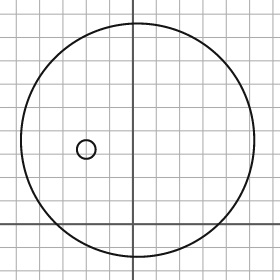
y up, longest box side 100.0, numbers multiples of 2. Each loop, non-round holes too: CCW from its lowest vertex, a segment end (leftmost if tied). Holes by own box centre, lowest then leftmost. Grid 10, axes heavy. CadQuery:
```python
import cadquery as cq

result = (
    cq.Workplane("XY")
    .moveTo(2.0, 36.0)
    .circle(50.0)
    .moveTo(-20.0, 32.0)
    .circle(4.0)
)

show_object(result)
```